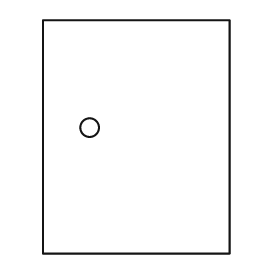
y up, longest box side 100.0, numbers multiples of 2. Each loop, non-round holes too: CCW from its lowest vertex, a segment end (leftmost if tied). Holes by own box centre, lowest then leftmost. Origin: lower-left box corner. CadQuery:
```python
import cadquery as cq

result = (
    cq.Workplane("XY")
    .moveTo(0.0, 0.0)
    .lineTo(80.0, 0.0)
    .lineTo(80.0, 100.0)
    .lineTo(0.0, 100.0)
    .close()
    .moveTo(20.0, 54.0)
    .circle(4.0)
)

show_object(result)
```